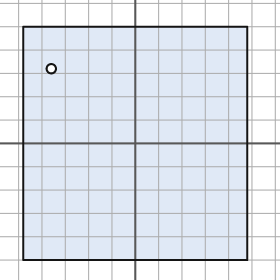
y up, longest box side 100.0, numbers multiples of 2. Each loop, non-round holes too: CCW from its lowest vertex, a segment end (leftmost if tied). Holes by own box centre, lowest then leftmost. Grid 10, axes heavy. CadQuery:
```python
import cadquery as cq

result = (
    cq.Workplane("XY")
    .moveTo(-48.0, -50.0)
    .lineTo(48.0, -50.0)
    .lineTo(48.0, 50.0)
    .lineTo(-48.0, 50.0)
    .close()
    .moveTo(-36.0, 32.0)
    .circle(2.0)
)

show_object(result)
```